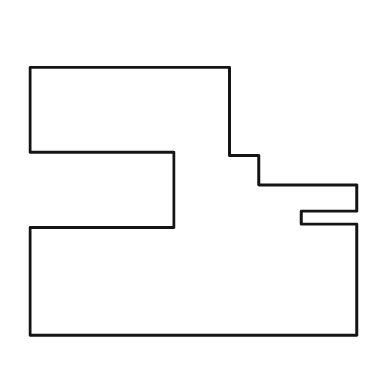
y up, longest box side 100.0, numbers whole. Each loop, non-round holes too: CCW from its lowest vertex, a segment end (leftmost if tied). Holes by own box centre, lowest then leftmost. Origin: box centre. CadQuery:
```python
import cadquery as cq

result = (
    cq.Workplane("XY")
    .moveTo(-50.0, -41.0)
    .lineTo(50.0, -41.0)
    .lineTo(50.0, -7.0)
    .lineTo(33.0, -7.0)
    .lineTo(33.0, -3.0)
    .lineTo(50.0, -3.0)
    .lineTo(50.0, 5.0)
    .lineTo(20.0, 5.0)
    .lineTo(20.0, 14.0)
    .lineTo(11.0, 14.0)
    .lineTo(11.0, 41.0)
    .lineTo(-50.0, 41.0)
    .lineTo(-50.0, 15.0)
    .lineTo(-6.0, 15.0)
    .lineTo(-6.0, -8.0)
    .lineTo(-50.0, -8.0)
    .close()
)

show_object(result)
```